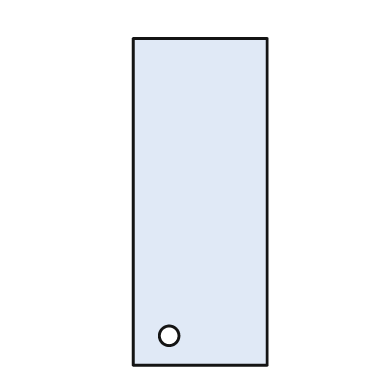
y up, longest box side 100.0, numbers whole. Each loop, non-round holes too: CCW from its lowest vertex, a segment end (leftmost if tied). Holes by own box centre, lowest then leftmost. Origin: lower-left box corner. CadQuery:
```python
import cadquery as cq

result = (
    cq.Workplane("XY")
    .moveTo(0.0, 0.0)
    .lineTo(41.0, 0.0)
    .lineTo(41.0, 100.0)
    .lineTo(0.0, 100.0)
    .close()
    .moveTo(11.0, 9.0)
    .circle(3.0)
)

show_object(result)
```